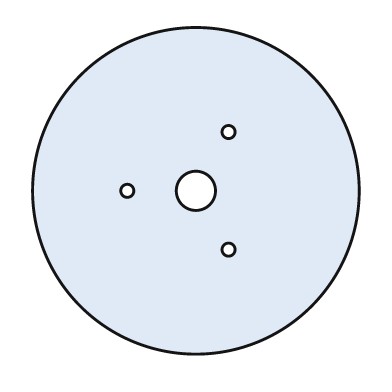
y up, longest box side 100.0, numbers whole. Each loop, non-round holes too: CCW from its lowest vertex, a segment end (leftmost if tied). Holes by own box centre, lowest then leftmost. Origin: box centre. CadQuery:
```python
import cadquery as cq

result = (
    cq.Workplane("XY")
    .moveTo(0.0, 0.0)
    .circle(50.0)
    .moveTo(10.0, -18.0)
    .circle(2.0)
    .moveTo(-21.0, 0.0)
    .circle(2.0)
    .moveTo(0.0, 0.0)
    .circle(6.0)
    .moveTo(10.0, 18.0)
    .circle(2.0)
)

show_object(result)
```